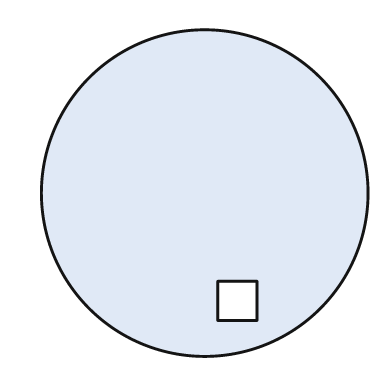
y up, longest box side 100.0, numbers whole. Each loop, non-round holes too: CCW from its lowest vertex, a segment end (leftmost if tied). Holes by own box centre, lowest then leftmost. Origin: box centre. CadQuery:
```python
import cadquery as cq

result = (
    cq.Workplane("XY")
    .moveTo(0.0, 0.0)
    .circle(50.0)
    .moveTo(4.0, -39.0)
    .lineTo(16.0, -39.0)
    .lineTo(16.0, -27.0)
    .lineTo(4.0, -27.0)
    .close()
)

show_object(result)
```